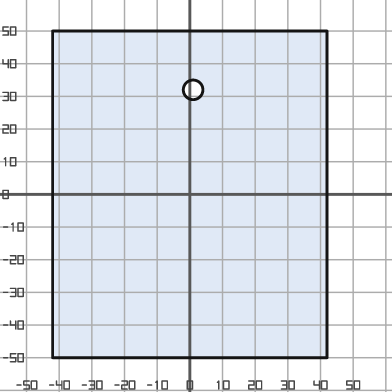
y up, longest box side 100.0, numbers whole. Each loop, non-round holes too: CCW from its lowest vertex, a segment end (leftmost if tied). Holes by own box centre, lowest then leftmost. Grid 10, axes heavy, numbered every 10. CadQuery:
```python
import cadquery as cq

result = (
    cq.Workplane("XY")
    .moveTo(-42.0, -50.0)
    .lineTo(42.0, -50.0)
    .lineTo(42.0, 50.0)
    .lineTo(-42.0, 50.0)
    .close()
    .moveTo(1.0, 32.0)
    .circle(3.0)
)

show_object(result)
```